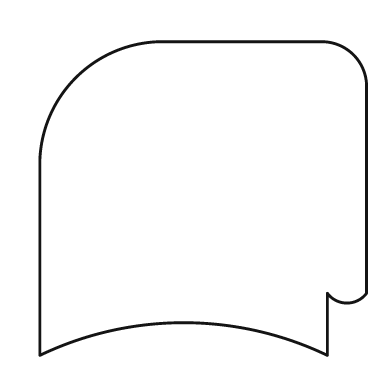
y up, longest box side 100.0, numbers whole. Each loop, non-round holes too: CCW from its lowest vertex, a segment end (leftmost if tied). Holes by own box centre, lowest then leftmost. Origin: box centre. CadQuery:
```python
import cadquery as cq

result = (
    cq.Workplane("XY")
    .moveTo(-50.0, -48.0)
    .threePointArc((-6.0, -38.0), (38.0, -48.0))
    .lineTo(38.0, -29.0)
    .threePointArc((44.0, -32.0), (50.0, -29.0))
    .lineTo(50.0, 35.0)
    .threePointArc((46.0, 44.0), (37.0, 48.0))
    .lineTo(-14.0, 48.0)
    .threePointArc((-39.0, 37.0), (-50.0, 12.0))
    .close()
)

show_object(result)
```